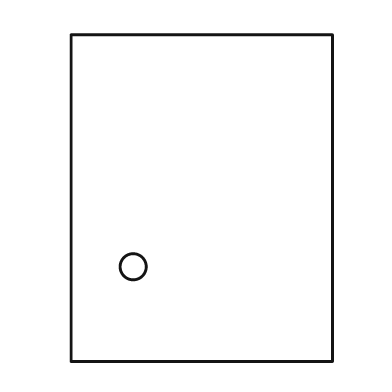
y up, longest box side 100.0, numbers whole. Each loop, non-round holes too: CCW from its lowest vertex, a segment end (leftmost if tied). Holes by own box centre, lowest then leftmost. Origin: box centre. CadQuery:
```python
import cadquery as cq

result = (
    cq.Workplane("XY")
    .moveTo(-40.0, -50.0)
    .lineTo(40.0, -50.0)
    .lineTo(40.0, 50.0)
    .lineTo(-40.0, 50.0)
    .close()
    .moveTo(-21.0, -21.0)
    .circle(4.0)
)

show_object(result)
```